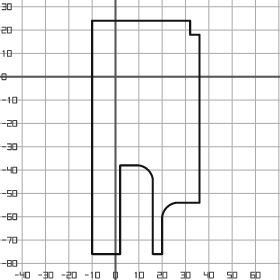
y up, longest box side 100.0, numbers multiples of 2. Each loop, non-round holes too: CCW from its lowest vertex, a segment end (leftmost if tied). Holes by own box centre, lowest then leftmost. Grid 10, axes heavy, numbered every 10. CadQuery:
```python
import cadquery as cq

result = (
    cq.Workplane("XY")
    .moveTo(-10.0, -76.0)
    .lineTo(2.0, -76.0)
    .lineTo(2.0, -38.0)
    .lineTo(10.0, -38.0)
    .threePointArc((14.0, -40.0), (16.0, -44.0))
    .lineTo(16.0, -76.0)
    .lineTo(20.0, -76.0)
    .lineTo(20.0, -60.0)
    .threePointArc((22.0, -56.0), (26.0, -54.0))
    .lineTo(36.0, -54.0)
    .lineTo(36.0, 18.0)
    .lineTo(32.0, 18.0)
    .lineTo(32.0, 24.0)
    .lineTo(-10.0, 24.0)
    .close()
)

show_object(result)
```